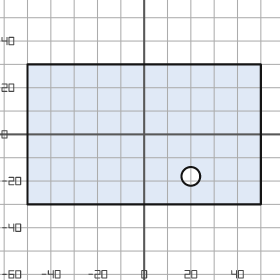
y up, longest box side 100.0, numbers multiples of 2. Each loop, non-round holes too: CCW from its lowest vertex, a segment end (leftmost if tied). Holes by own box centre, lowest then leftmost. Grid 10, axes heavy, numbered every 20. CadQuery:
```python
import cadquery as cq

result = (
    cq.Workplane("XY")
    .moveTo(-50.0, -30.0)
    .lineTo(50.0, -30.0)
    .lineTo(50.0, 30.0)
    .lineTo(-50.0, 30.0)
    .close()
    .moveTo(20.0, -18.0)
    .circle(4.0)
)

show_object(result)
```